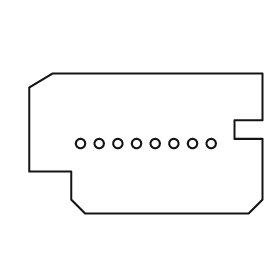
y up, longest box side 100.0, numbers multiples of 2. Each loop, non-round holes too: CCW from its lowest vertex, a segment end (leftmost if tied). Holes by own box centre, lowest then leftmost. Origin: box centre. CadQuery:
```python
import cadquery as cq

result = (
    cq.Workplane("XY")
    .moveTo(-26.0, -30.0)
    .lineTo(44.0, -30.0)
    .lineTo(50.0, -24.0)
    .lineTo(50.0, 2.0)
    .lineTo(38.0, 2.0)
    .lineTo(38.0, 10.0)
    .lineTo(50.0, 10.0)
    .lineTo(50.0, 30.0)
    .lineTo(-40.0, 30.0)
    .lineTo(-50.0, 24.0)
    .lineTo(-50.0, -12.0)
    .lineTo(-32.0, -12.0)
    .lineTo(-32.0, -24.0)
    .close()
    .moveTo(-28.0, 0.0)
    .circle(2.0)
    .moveTo(-20.0, 0.0)
    .circle(2.0)
    .moveTo(-12.0, 0.0)
    .circle(2.0)
    .moveTo(-4.0, 0.0)
    .circle(2.0)
    .moveTo(4.0, 0.0)
    .circle(2.0)
    .moveTo(12.0, 0.0)
    .circle(2.0)
    .moveTo(20.0, 0.0)
    .circle(2.0)
    .moveTo(28.0, 0.0)
    .circle(2.0)
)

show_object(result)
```